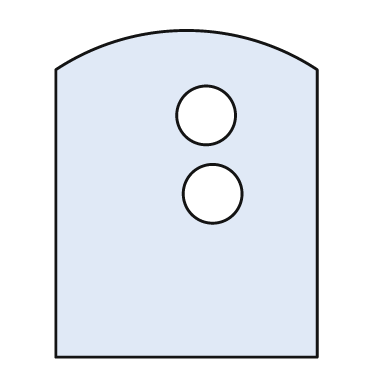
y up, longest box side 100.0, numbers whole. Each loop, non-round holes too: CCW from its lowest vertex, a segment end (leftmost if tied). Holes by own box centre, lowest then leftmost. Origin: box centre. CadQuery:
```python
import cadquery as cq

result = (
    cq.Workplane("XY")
    .moveTo(-40.0, -50.0)
    .lineTo(40.0, -50.0)
    .lineTo(40.0, 38.0)
    .threePointArc((0.0, 50.0), (-40.0, 38.0))
    .close()
    .moveTo(8.0, 0.0)
    .circle(9.0)
    .moveTo(6.0, 24.0)
    .circle(9.0)
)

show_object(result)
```